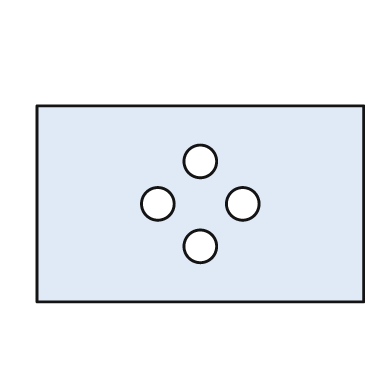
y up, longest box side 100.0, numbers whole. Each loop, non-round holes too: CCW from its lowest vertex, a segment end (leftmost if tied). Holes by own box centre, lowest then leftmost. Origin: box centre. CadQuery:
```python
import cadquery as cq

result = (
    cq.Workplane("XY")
    .moveTo(-50.0, -30.0)
    .lineTo(50.0, -30.0)
    .lineTo(50.0, 30.0)
    .lineTo(-50.0, 30.0)
    .close()
    .moveTo(0.0, -13.0)
    .circle(5.0)
    .moveTo(-13.0, 0.0)
    .circle(5.0)
    .moveTo(13.0, 0.0)
    .circle(5.0)
    .moveTo(0.0, 13.0)
    .circle(5.0)
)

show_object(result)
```